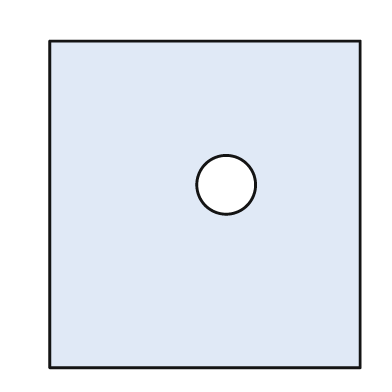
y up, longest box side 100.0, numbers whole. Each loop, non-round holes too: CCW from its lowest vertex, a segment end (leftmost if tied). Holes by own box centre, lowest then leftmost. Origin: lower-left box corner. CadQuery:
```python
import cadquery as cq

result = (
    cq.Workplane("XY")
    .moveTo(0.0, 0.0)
    .lineTo(95.0, 0.0)
    .lineTo(95.0, 100.0)
    .lineTo(0.0, 100.0)
    .close()
    .moveTo(54.0, 56.0)
    .circle(9.0)
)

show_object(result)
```